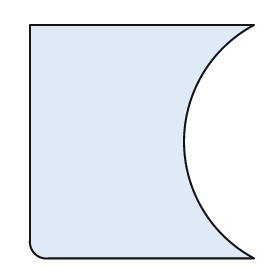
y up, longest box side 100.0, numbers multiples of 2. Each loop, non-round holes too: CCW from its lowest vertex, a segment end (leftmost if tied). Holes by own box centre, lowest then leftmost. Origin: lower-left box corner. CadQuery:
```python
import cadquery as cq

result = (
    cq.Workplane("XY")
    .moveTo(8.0, 0.0)
    .lineTo(96.0, 0.0)
    .threePointArc((66.0, 50.0), (96.0, 100.0))
    .lineTo(0.0, 100.0)
    .lineTo(0.0, 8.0)
    .threePointArc((2.0, 2.0), (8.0, 0.0))
    .close()
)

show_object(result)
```